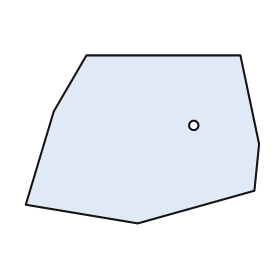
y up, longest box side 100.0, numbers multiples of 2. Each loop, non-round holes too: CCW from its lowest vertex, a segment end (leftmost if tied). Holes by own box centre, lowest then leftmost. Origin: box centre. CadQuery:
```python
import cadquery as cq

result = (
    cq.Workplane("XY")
    .moveTo(-2.0, -36.0)
    .lineTo(48.0, -22.0)
    .lineTo(50.0, -2.0)
    .lineTo(42.0, 36.0)
    .lineTo(-24.0, 36.0)
    .lineTo(-38.0, 12.0)
    .lineTo(-50.0, -28.0)
    .close()
    .moveTo(22.0, 6.0)
    .circle(2.0)
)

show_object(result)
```